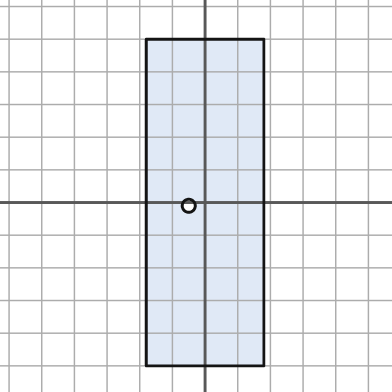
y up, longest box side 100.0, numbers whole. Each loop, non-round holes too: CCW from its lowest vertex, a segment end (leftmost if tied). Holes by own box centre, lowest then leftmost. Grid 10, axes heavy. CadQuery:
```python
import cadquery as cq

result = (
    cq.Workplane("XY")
    .moveTo(-18.0, -50.0)
    .lineTo(18.0, -50.0)
    .lineTo(18.0, 50.0)
    .lineTo(-18.0, 50.0)
    .close()
    .moveTo(-5.0, -1.0)
    .circle(2.0)
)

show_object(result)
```